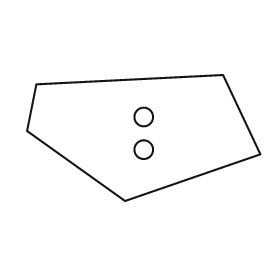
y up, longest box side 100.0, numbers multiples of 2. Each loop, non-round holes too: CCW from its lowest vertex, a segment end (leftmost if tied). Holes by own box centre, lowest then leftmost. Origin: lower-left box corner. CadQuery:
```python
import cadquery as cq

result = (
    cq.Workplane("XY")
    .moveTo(42.0, 0.0)
    .lineTo(100.0, 20.0)
    .lineTo(84.0, 54.0)
    .lineTo(4.0, 50.0)
    .lineTo(0.0, 30.0)
    .close()
    .moveTo(50.0, 22.0)
    .circle(4.0)
    .moveTo(50.0, 36.0)
    .circle(4.0)
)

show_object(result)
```